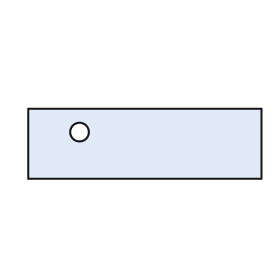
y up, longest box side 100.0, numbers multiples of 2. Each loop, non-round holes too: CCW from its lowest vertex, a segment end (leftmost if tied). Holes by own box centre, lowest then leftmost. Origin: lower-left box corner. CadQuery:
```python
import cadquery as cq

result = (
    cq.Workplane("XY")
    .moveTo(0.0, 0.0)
    .lineTo(100.0, 0.0)
    .lineTo(100.0, 30.0)
    .lineTo(0.0, 30.0)
    .close()
    .moveTo(22.0, 20.0)
    .circle(4.0)
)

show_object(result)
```